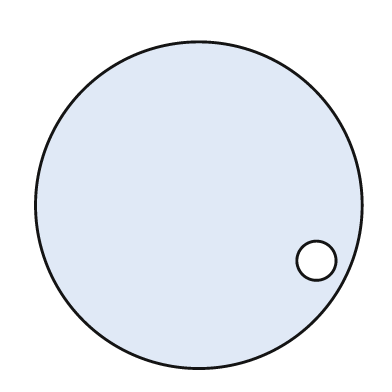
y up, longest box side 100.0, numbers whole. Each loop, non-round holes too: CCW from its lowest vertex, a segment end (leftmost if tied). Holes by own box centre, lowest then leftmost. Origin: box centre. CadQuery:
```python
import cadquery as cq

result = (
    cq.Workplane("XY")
    .moveTo(0.0, 0.0)
    .circle(50.0)
    .moveTo(36.0, -17.0)
    .circle(6.0)
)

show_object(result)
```